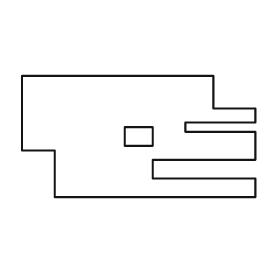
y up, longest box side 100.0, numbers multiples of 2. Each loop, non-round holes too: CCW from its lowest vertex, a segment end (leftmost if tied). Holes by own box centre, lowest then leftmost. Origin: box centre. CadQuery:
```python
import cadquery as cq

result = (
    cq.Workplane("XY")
    .moveTo(-36.0, -26.0)
    .lineTo(50.0, -26.0)
    .lineTo(50.0, -18.0)
    .lineTo(6.0, -18.0)
    .lineTo(6.0, -10.0)
    .lineTo(50.0, -10.0)
    .lineTo(50.0, 2.0)
    .lineTo(20.0, 2.0)
    .lineTo(20.0, 6.0)
    .lineTo(50.0, 6.0)
    .lineTo(50.0, 12.0)
    .lineTo(32.0, 12.0)
    .lineTo(32.0, 26.0)
    .lineTo(-50.0, 26.0)
    .lineTo(-50.0, -6.0)
    .lineTo(-36.0, -6.0)
    .close()
    .moveTo(-6.0, -4.0)
    .lineTo(6.0, -4.0)
    .lineTo(6.0, 4.0)
    .lineTo(-6.0, 4.0)
    .close()
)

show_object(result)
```